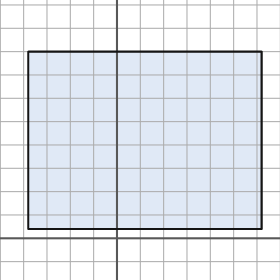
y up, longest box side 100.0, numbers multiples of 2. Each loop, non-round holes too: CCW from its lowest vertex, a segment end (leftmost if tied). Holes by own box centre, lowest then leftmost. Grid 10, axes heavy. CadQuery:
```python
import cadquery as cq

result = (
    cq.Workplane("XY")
    .moveTo(-38.0, 4.0)
    .lineTo(62.0, 4.0)
    .lineTo(62.0, 80.0)
    .lineTo(-38.0, 80.0)
    .close()
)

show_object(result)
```